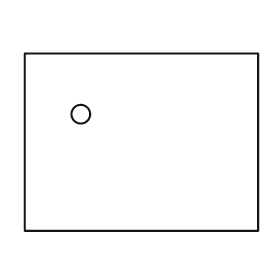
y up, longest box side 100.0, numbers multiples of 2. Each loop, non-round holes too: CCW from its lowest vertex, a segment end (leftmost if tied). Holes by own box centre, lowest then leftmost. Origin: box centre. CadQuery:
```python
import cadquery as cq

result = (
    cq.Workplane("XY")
    .moveTo(-50.0, -38.0)
    .lineTo(50.0, -38.0)
    .lineTo(50.0, 38.0)
    .lineTo(-50.0, 38.0)
    .close()
    .moveTo(-26.0, 12.0)
    .circle(4.0)
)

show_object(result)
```